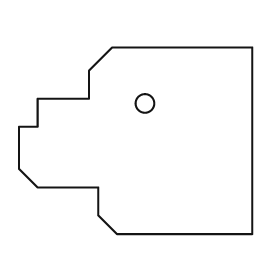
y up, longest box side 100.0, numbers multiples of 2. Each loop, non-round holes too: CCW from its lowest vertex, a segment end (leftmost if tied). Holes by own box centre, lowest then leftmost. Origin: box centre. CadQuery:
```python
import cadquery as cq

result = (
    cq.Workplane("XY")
    .moveTo(-8.0, -40.0)
    .lineTo(50.0, -40.0)
    .lineTo(50.0, 40.0)
    .lineTo(-10.0, 40.0)
    .lineTo(-20.0, 30.0)
    .lineTo(-20.0, 18.0)
    .lineTo(-42.0, 18.0)
    .lineTo(-42.0, 6.0)
    .lineTo(-50.0, 6.0)
    .lineTo(-50.0, -12.0)
    .lineTo(-42.0, -20.0)
    .lineTo(-16.0, -20.0)
    .lineTo(-16.0, -32.0)
    .close()
    .moveTo(4.0, 16.0)
    .circle(4.0)
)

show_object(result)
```